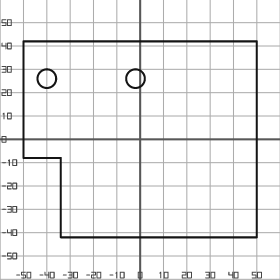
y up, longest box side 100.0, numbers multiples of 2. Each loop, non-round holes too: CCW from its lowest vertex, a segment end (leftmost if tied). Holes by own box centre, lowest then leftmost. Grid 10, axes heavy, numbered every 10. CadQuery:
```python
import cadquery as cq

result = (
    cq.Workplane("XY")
    .moveTo(-34.0, -42.0)
    .lineTo(50.0, -42.0)
    .lineTo(50.0, 42.0)
    .lineTo(-50.0, 42.0)
    .lineTo(-50.0, -8.0)
    .lineTo(-34.0, -8.0)
    .close()
    .moveTo(-40.0, 26.0)
    .circle(4.0)
    .moveTo(-2.0, 26.0)
    .circle(4.0)
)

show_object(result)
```